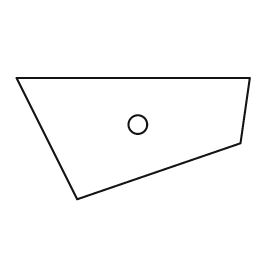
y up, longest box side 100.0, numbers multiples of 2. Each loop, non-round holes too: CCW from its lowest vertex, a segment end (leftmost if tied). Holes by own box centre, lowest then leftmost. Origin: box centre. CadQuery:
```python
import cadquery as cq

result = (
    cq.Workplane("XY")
    .moveTo(-24.0, -26.0)
    .lineTo(46.0, -2.0)
    .lineTo(50.0, 26.0)
    .lineTo(-50.0, 26.0)
    .close()
    .moveTo(2.0, 6.0)
    .circle(4.0)
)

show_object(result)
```